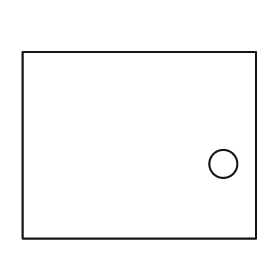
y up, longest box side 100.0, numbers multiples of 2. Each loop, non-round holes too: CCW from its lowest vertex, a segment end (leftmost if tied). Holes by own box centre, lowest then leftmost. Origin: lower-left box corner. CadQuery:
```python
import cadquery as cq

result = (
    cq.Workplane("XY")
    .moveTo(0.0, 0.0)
    .lineTo(100.0, 0.0)
    .lineTo(100.0, 80.0)
    .lineTo(0.0, 80.0)
    .close()
    .moveTo(86.0, 32.0)
    .circle(6.0)
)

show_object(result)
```